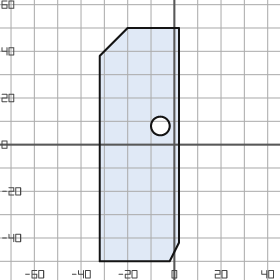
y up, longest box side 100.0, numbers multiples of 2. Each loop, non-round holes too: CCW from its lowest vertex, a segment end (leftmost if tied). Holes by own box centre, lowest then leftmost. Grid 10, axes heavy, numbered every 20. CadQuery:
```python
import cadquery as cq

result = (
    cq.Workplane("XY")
    .moveTo(-32.0, -50.0)
    .lineTo(-2.0, -50.0)
    .lineTo(2.0, -42.0)
    .lineTo(2.0, 50.0)
    .lineTo(-20.0, 50.0)
    .lineTo(-32.0, 38.0)
    .close()
    .moveTo(-6.0, 8.0)
    .circle(4.0)
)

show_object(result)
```